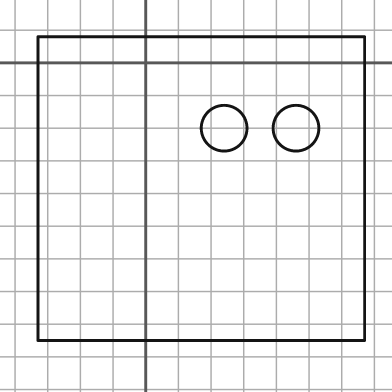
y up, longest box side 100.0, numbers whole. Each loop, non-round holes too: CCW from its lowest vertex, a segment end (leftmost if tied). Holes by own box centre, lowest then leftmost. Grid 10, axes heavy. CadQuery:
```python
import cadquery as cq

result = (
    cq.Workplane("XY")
    .moveTo(-33.0, -85.0)
    .lineTo(67.0, -85.0)
    .lineTo(67.0, 8.0)
    .lineTo(-33.0, 8.0)
    .close()
    .moveTo(24.0, -20.0)
    .circle(7.0)
    .moveTo(46.0, -20.0)
    .circle(7.0)
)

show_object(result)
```